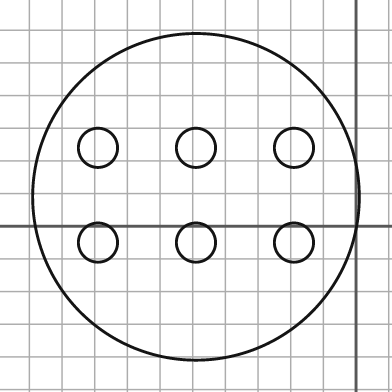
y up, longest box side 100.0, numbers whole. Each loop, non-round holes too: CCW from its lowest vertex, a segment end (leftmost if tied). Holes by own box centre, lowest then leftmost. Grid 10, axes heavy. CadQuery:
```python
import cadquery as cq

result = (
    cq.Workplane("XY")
    .moveTo(-49.0, 9.0)
    .circle(50.0)
    .moveTo(-79.0, -5.0)
    .circle(6.0)
    .moveTo(-49.0, -5.0)
    .circle(6.0)
    .moveTo(-19.0, -5.0)
    .circle(6.0)
    .moveTo(-79.0, 24.0)
    .circle(6.0)
    .moveTo(-49.0, 24.0)
    .circle(6.0)
    .moveTo(-19.0, 24.0)
    .circle(6.0)
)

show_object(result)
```